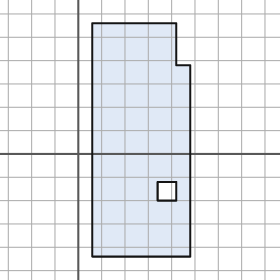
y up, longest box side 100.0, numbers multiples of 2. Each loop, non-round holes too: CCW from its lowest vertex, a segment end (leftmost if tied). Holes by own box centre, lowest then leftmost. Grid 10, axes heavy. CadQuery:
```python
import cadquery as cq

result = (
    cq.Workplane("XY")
    .moveTo(6.0, -44.0)
    .lineTo(48.0, -44.0)
    .lineTo(48.0, 38.0)
    .lineTo(42.0, 38.0)
    .lineTo(42.0, 56.0)
    .lineTo(6.0, 56.0)
    .close()
    .moveTo(34.0, -20.0)
    .lineTo(42.0, -20.0)
    .lineTo(42.0, -12.0)
    .lineTo(34.0, -12.0)
    .close()
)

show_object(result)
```